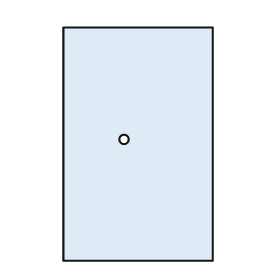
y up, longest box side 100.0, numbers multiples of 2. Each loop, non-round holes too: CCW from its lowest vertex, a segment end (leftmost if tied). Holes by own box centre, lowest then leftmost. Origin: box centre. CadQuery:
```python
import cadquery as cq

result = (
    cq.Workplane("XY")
    .moveTo(-32.0, -50.0)
    .lineTo(32.0, -50.0)
    .lineTo(32.0, 50.0)
    .lineTo(-32.0, 50.0)
    .close()
    .moveTo(-6.0, 2.0)
    .circle(2.0)
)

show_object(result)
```